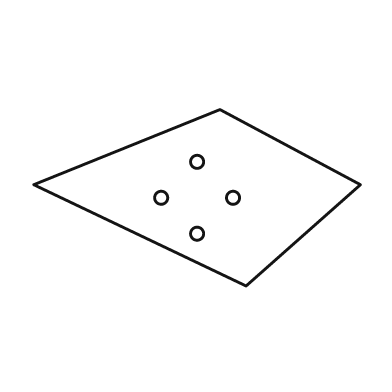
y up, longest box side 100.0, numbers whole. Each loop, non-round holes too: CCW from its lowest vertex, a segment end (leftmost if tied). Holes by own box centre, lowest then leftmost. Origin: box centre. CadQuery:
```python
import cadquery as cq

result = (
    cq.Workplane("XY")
    .moveTo(15.0, -27.0)
    .lineTo(50.0, 4.0)
    .lineTo(7.0, 27.0)
    .lineTo(-50.0, 4.0)
    .close()
    .moveTo(0.0, -11.0)
    .circle(2.0)
    .moveTo(-11.0, 0.0)
    .circle(2.0)
    .moveTo(11.0, 0.0)
    .circle(2.0)
    .moveTo(0.0, 11.0)
    .circle(2.0)
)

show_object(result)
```